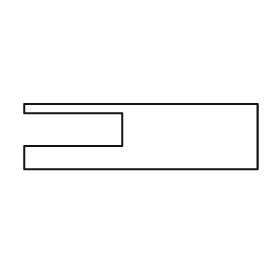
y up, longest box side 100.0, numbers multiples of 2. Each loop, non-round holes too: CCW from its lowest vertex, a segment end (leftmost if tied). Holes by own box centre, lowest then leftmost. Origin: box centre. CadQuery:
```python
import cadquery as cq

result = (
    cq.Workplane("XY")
    .moveTo(-50.0, -14.0)
    .lineTo(50.0, -14.0)
    .lineTo(50.0, 14.0)
    .lineTo(-50.0, 14.0)
    .lineTo(-50.0, 10.0)
    .lineTo(-8.0, 10.0)
    .lineTo(-8.0, -4.0)
    .lineTo(-50.0, -4.0)
    .close()
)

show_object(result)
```